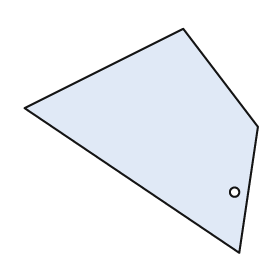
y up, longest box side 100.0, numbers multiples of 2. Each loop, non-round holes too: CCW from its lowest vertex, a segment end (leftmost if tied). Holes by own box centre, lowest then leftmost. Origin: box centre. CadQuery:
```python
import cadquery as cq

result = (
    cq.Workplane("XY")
    .moveTo(42.0, -48.0)
    .lineTo(50.0, 6.0)
    .lineTo(18.0, 48.0)
    .lineTo(-50.0, 14.0)
    .close()
    .moveTo(40.0, -22.0)
    .circle(2.0)
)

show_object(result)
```